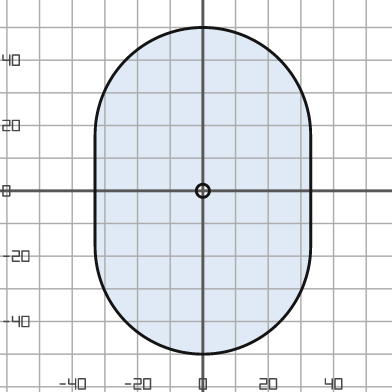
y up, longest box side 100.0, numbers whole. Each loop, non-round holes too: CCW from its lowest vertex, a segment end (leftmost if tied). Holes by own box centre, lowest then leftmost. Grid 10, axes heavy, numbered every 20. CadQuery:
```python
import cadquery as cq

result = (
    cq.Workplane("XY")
    .moveTo(-33.0, -17.0)
    .threePointArc((0.0, -50.0), (33.0, -17.0))
    .lineTo(33.0, 17.0)
    .threePointArc((0.0, 50.0), (-33.0, 17.0))
    .close()
    .moveTo(0.0, 0.0)
    .circle(2.0)
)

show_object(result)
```